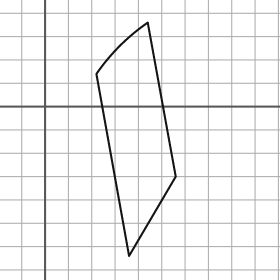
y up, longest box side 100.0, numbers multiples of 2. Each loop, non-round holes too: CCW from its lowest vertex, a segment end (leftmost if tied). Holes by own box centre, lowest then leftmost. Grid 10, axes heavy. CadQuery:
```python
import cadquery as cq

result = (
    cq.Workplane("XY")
    .moveTo(36.0, -64.0)
    .lineTo(56.0, -30.0)
    .lineTo(44.0, 36.0)
    .threePointArc((32.0, 26.0), (22.0, 14.0))
    .close()
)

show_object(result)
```